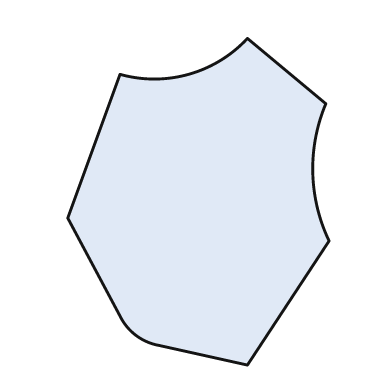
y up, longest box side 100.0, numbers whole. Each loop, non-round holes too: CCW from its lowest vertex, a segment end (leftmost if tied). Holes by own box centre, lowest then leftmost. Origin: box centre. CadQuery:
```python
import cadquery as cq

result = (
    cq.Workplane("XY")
    .moveTo(15.0, -50.0)
    .lineTo(40.0, -12.0)
    .threePointArc((35.0, 9.0), (39.0, 30.0))
    .lineTo(15.0, 50.0)
    .threePointArc((-3.0, 39.0), (-24.0, 39.0))
    .lineTo(-40.0, -5.0)
    .lineTo(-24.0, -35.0)
    .threePointArc((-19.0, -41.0), (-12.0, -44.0))
    .close()
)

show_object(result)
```